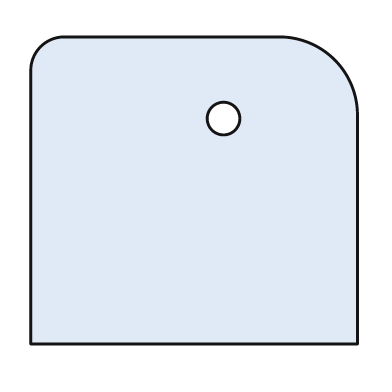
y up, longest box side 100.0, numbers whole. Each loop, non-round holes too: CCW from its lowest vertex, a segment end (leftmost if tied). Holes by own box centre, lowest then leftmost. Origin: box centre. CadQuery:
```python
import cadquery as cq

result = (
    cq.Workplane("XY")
    .moveTo(-50.0, -47.0)
    .lineTo(50.0, -47.0)
    .lineTo(50.0, 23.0)
    .threePointArc((43.0, 40.0), (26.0, 47.0))
    .lineTo(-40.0, 47.0)
    .threePointArc((-47.0, 44.0), (-50.0, 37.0))
    .close()
    .moveTo(9.0, 22.0)
    .circle(5.0)
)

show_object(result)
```